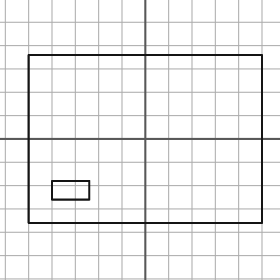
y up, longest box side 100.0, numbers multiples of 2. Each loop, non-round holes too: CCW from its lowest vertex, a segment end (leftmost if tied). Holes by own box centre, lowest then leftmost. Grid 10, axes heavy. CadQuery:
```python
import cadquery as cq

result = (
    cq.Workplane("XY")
    .moveTo(-50.0, -36.0)
    .lineTo(50.0, -36.0)
    .lineTo(50.0, 36.0)
    .lineTo(-50.0, 36.0)
    .close()
    .moveTo(-40.0, -26.0)
    .lineTo(-24.0, -26.0)
    .lineTo(-24.0, -18.0)
    .lineTo(-40.0, -18.0)
    .close()
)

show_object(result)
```